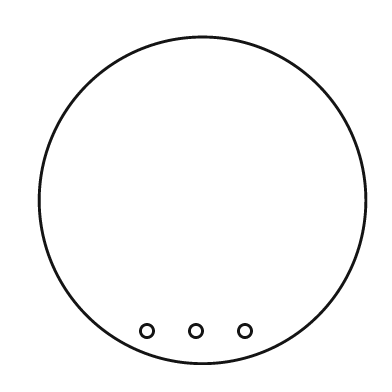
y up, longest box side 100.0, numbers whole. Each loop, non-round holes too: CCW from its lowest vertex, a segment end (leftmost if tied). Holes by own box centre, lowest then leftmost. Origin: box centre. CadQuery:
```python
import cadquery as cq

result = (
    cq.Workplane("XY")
    .moveTo(0.0, 0.0)
    .circle(50.0)
    .moveTo(-17.0, -40.0)
    .circle(2.0)
    .moveTo(-2.0, -40.0)
    .circle(2.0)
    .moveTo(13.0, -40.0)
    .circle(2.0)
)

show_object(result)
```